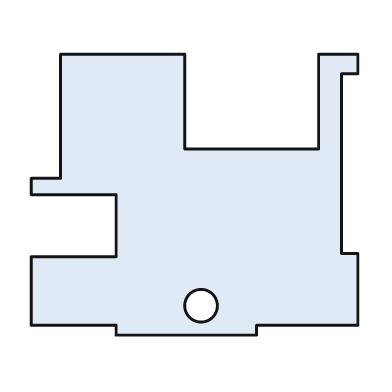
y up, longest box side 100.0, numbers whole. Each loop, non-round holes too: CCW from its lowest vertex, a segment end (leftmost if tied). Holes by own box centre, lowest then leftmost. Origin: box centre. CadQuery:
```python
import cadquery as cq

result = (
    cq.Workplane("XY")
    .moveTo(-24.0, -43.0)
    .lineTo(19.0, -43.0)
    .lineTo(19.0, -40.0)
    .lineTo(50.0, -40.0)
    .lineTo(50.0, -18.0)
    .lineTo(45.0, -18.0)
    .lineTo(45.0, 37.0)
    .lineTo(50.0, 37.0)
    .lineTo(50.0, 43.0)
    .lineTo(38.0, 43.0)
    .lineTo(38.0, 14.0)
    .lineTo(-3.0, 14.0)
    .lineTo(-3.0, 43.0)
    .lineTo(-41.0, 43.0)
    .lineTo(-41.0, 5.0)
    .lineTo(-50.0, 5.0)
    .lineTo(-50.0, 0.0)
    .lineTo(-24.0, 0.0)
    .lineTo(-24.0, -19.0)
    .lineTo(-50.0, -19.0)
    .lineTo(-50.0, -40.0)
    .lineTo(-24.0, -40.0)
    .close()
    .moveTo(2.0, -34.0)
    .circle(5.0)
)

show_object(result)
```